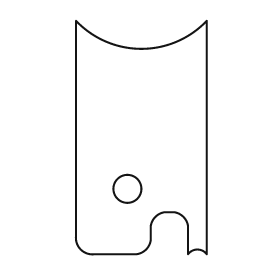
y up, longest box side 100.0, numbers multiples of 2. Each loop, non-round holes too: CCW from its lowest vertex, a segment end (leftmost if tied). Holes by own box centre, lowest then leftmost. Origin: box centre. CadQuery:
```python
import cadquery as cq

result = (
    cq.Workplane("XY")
    .moveTo(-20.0, -50.0)
    .lineTo(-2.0, -50.0)
    .threePointArc((2.0, -48.0), (4.0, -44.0))
    .lineTo(4.0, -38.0)
    .threePointArc((6.0, -34.0), (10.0, -32.0))
    .lineTo(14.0, -32.0)
    .threePointArc((18.0, -34.0), (20.0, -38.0))
    .lineTo(20.0, -50.0)
    .threePointArc((24.0, -48.0), (28.0, -50.0))
    .lineTo(28.0, 50.0)
    .threePointArc((0.0, 38.0), (-28.0, 50.0))
    .lineTo(-28.0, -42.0)
    .threePointArc((-26.0, -48.0), (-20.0, -50.0))
    .close()
    .moveTo(-6.0, -22.0)
    .circle(6.0)
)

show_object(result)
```